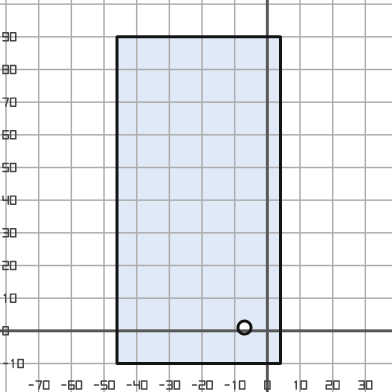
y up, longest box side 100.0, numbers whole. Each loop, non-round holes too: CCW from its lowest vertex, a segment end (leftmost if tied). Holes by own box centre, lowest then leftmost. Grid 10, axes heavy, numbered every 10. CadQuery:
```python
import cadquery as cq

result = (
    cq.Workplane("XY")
    .moveTo(-46.0, -10.0)
    .lineTo(4.0, -10.0)
    .lineTo(4.0, 90.0)
    .lineTo(-46.0, 90.0)
    .close()
    .moveTo(-7.0, 1.0)
    .circle(2.0)
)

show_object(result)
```